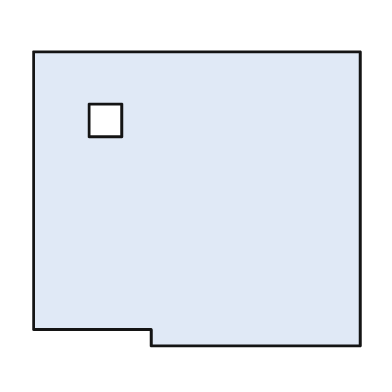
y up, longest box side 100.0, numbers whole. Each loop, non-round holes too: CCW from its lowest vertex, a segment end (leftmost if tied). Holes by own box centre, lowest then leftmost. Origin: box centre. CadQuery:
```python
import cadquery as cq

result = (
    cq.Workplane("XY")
    .moveTo(-14.0, -45.0)
    .lineTo(50.0, -45.0)
    .lineTo(50.0, 45.0)
    .lineTo(-50.0, 45.0)
    .lineTo(-50.0, -40.0)
    .lineTo(-14.0, -40.0)
    .close()
    .moveTo(-33.0, 19.0)
    .lineTo(-23.0, 19.0)
    .lineTo(-23.0, 29.0)
    .lineTo(-33.0, 29.0)
    .close()
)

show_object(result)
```